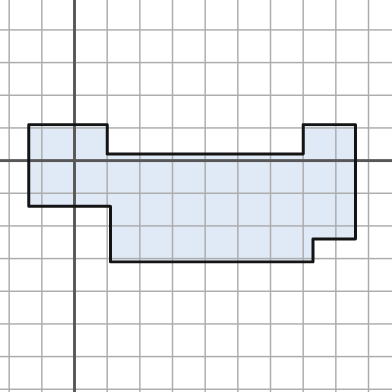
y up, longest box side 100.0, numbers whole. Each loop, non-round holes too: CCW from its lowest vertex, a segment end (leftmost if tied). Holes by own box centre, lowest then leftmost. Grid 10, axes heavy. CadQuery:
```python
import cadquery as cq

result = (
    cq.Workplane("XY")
    .moveTo(11.0, -31.0)
    .lineTo(73.0, -31.0)
    .lineTo(73.0, -24.0)
    .lineTo(86.0, -24.0)
    .lineTo(86.0, 11.0)
    .lineTo(70.0, 11.0)
    .lineTo(70.0, 2.0)
    .lineTo(10.0, 2.0)
    .lineTo(10.0, 11.0)
    .lineTo(-14.0, 11.0)
    .lineTo(-14.0, -14.0)
    .lineTo(11.0, -14.0)
    .close()
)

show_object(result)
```